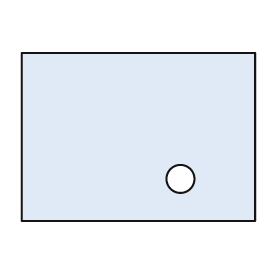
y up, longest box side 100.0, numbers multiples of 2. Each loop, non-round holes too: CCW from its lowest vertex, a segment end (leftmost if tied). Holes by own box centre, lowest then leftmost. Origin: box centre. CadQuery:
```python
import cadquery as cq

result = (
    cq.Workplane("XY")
    .moveTo(-50.0, -36.0)
    .lineTo(50.0, -36.0)
    .lineTo(50.0, 36.0)
    .lineTo(-50.0, 36.0)
    .close()
    .moveTo(18.0, -18.0)
    .circle(6.0)
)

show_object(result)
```